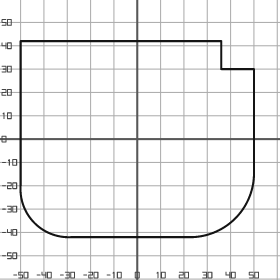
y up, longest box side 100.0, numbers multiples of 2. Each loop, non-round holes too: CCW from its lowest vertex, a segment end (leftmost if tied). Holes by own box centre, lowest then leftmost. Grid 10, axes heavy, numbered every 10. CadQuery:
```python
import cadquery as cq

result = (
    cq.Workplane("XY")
    .moveTo(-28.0, -42.0)
    .lineTo(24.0, -42.0)
    .threePointArc((42.0, -34.0), (50.0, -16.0))
    .lineTo(50.0, 30.0)
    .lineTo(36.0, 30.0)
    .lineTo(36.0, 42.0)
    .lineTo(-50.0, 42.0)
    .lineTo(-50.0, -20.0)
    .threePointArc((-44.0, -36.0), (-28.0, -42.0))
    .close()
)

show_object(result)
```